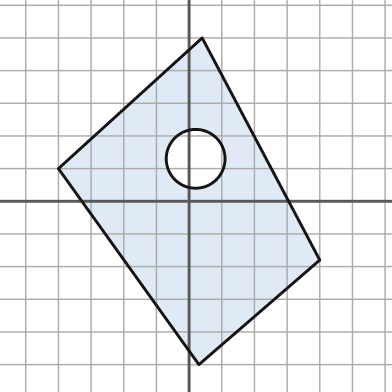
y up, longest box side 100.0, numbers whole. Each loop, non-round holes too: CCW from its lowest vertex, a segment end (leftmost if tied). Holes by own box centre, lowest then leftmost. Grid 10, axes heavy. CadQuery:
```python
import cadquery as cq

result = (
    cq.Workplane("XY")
    .moveTo(3.0, -50.0)
    .lineTo(40.0, -18.0)
    .lineTo(4.0, 50.0)
    .lineTo(-40.0, 10.0)
    .close()
    .moveTo(2.0, 13.0)
    .circle(9.0)
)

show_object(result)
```